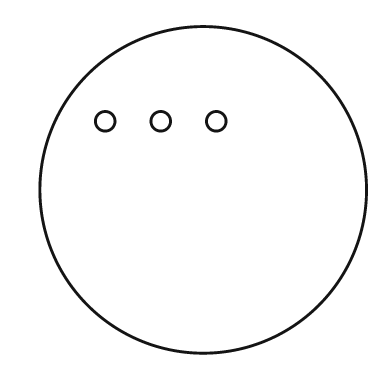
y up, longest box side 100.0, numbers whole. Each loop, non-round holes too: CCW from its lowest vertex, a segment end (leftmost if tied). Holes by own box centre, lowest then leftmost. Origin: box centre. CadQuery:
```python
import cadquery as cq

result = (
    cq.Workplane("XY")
    .moveTo(0.0, 0.0)
    .circle(50.0)
    .moveTo(-30.0, 21.0)
    .circle(3.0)
    .moveTo(-13.0, 21.0)
    .circle(3.0)
    .moveTo(4.0, 21.0)
    .circle(3.0)
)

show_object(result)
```